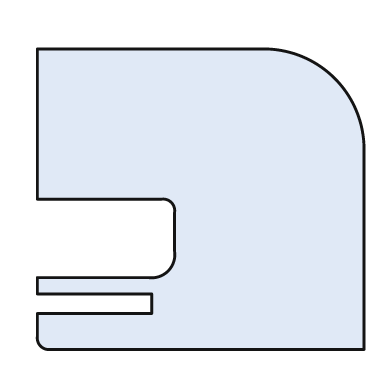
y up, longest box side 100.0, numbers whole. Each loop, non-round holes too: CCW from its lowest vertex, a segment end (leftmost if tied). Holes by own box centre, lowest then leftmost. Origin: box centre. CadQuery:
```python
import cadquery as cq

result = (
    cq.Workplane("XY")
    .moveTo(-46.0, -46.0)
    .lineTo(50.0, -46.0)
    .lineTo(50.0, 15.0)
    .threePointArc((41.0, 37.0), (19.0, 46.0))
    .lineTo(-50.0, 46.0)
    .lineTo(-50.0, 0.0)
    .lineTo(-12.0, 0.0)
    .threePointArc((-9.0, -1.0), (-8.0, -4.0))
    .lineTo(-8.0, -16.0)
    .threePointArc((-10.0, -22.0), (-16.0, -24.0))
    .lineTo(-50.0, -24.0)
    .lineTo(-50.0, -29.0)
    .lineTo(-15.0, -29.0)
    .lineTo(-15.0, -35.0)
    .lineTo(-50.0, -35.0)
    .lineTo(-50.0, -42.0)
    .threePointArc((-49.0, -45.0), (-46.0, -46.0))
    .close()
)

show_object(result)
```